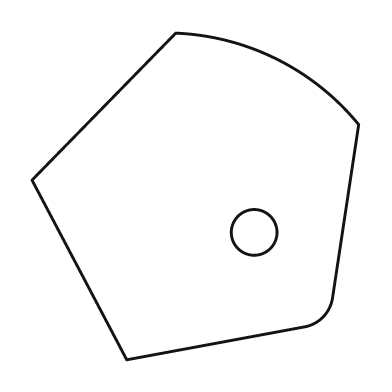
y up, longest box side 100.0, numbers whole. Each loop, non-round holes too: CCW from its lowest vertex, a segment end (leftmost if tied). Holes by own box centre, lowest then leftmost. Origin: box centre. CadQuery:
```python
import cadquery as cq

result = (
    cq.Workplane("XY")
    .moveTo(-21.0, -50.0)
    .lineTo(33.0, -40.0)
    .threePointArc((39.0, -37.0), (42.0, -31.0))
    .lineTo(50.0, 22.0)
    .threePointArc((25.0, 42.0), (-6.0, 50.0))
    .lineTo(-50.0, 5.0)
    .close()
    .moveTo(18.0, -11.0)
    .circle(7.0)
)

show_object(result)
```